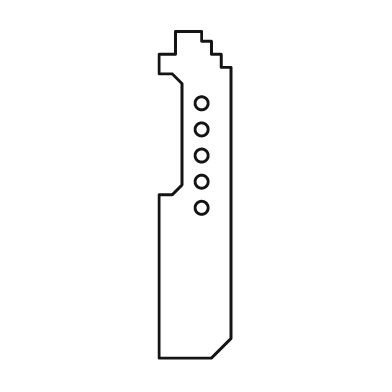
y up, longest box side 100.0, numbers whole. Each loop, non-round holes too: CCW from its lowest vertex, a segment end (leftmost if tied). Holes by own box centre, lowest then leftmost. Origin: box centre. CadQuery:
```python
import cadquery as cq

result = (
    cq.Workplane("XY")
    .moveTo(-11.0, -50.0)
    .lineTo(5.0, -50.0)
    .lineTo(11.0, -44.0)
    .lineTo(11.0, 39.0)
    .lineTo(8.0, 39.0)
    .lineTo(8.0, 43.0)
    .lineTo(5.0, 43.0)
    .lineTo(5.0, 47.0)
    .lineTo(2.0, 47.0)
    .lineTo(2.0, 50.0)
    .lineTo(-6.0, 50.0)
    .lineTo(-6.0, 43.0)
    .lineTo(-11.0, 43.0)
    .lineTo(-11.0, 37.0)
    .lineTo(-7.0, 37.0)
    .lineTo(-4.0, 34.0)
    .lineTo(-4.0, 3.0)
    .lineTo(-7.0, 0.0)
    .lineTo(-11.0, 0.0)
    .close()
    .moveTo(2.0, -4.0)
    .circle(2.0)
    .moveTo(2.0, 4.0)
    .circle(2.0)
    .moveTo(2.0, 12.0)
    .circle(2.0)
    .moveTo(2.0, 20.0)
    .circle(2.0)
    .moveTo(2.0, 28.0)
    .circle(2.0)
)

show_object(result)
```